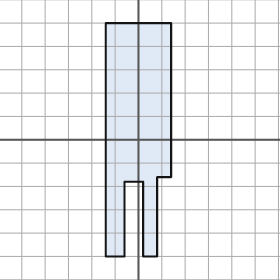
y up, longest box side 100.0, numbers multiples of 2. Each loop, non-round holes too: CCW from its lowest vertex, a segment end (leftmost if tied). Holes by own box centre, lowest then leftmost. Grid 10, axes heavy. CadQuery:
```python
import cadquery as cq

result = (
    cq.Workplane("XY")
    .moveTo(-14.0, -50.0)
    .lineTo(-6.0, -50.0)
    .lineTo(-6.0, -18.0)
    .lineTo(2.0, -18.0)
    .lineTo(2.0, -50.0)
    .lineTo(8.0, -50.0)
    .lineTo(8.0, -16.0)
    .lineTo(14.0, -16.0)
    .lineTo(14.0, 50.0)
    .lineTo(-14.0, 50.0)
    .close()
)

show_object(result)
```